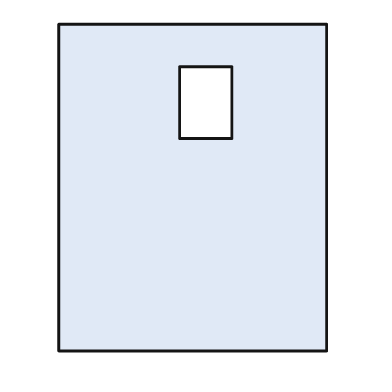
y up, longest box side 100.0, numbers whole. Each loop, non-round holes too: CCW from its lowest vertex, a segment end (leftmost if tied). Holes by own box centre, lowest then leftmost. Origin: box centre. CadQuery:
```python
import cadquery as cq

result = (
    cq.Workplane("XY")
    .moveTo(-41.0, -50.0)
    .lineTo(41.0, -50.0)
    .lineTo(41.0, 50.0)
    .lineTo(-41.0, 50.0)
    .close()
    .moveTo(-4.0, 15.0)
    .lineTo(12.0, 15.0)
    .lineTo(12.0, 37.0)
    .lineTo(-4.0, 37.0)
    .close()
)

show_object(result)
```